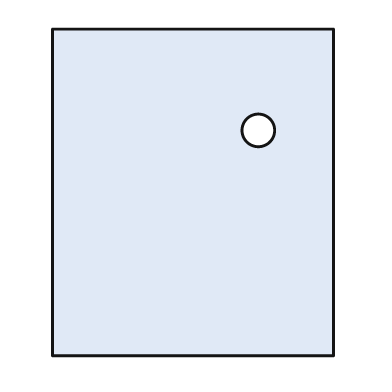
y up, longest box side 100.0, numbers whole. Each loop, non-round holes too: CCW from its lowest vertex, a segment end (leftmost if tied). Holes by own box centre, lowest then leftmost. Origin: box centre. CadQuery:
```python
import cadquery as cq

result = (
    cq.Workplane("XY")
    .moveTo(-43.0, -50.0)
    .lineTo(43.0, -50.0)
    .lineTo(43.0, 50.0)
    .lineTo(-43.0, 50.0)
    .close()
    .moveTo(20.0, 19.0)
    .circle(5.0)
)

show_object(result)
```